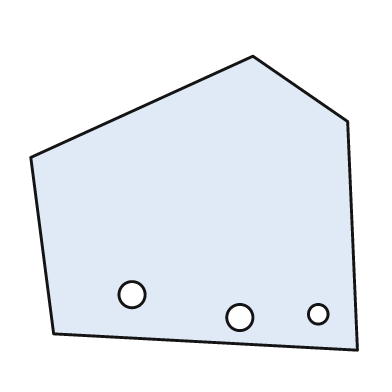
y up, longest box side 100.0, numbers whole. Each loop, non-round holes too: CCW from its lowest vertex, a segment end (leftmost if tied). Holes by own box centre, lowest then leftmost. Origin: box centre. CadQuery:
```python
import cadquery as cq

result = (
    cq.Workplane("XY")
    .moveTo(50.0, -45.0)
    .lineTo(47.0, 25.0)
    .lineTo(18.0, 45.0)
    .lineTo(-50.0, 14.0)
    .lineTo(-43.0, -40.0)
    .close()
    .moveTo(14.0, -35.0)
    .circle(4.0)
    .moveTo(38.0, -34.0)
    .circle(3.0)
    .moveTo(-19.0, -28.0)
    .circle(4.0)
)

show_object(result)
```